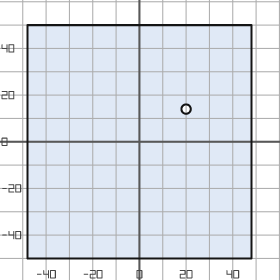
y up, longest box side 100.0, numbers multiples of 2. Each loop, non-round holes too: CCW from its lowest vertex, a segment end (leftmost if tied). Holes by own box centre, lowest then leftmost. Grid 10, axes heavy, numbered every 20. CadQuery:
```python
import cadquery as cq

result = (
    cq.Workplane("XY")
    .moveTo(-48.0, -50.0)
    .lineTo(48.0, -50.0)
    .lineTo(48.0, 50.0)
    .lineTo(-48.0, 50.0)
    .close()
    .moveTo(20.0, 14.0)
    .circle(2.0)
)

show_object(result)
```